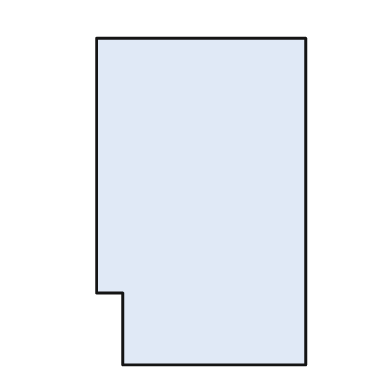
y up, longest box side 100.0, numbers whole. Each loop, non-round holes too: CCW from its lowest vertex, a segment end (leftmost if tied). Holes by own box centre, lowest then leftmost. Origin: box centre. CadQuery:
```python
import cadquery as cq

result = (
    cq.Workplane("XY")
    .moveTo(-24.0, -50.0)
    .lineTo(32.0, -50.0)
    .lineTo(32.0, 50.0)
    .lineTo(-32.0, 50.0)
    .lineTo(-32.0, -28.0)
    .lineTo(-24.0, -28.0)
    .close()
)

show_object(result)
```